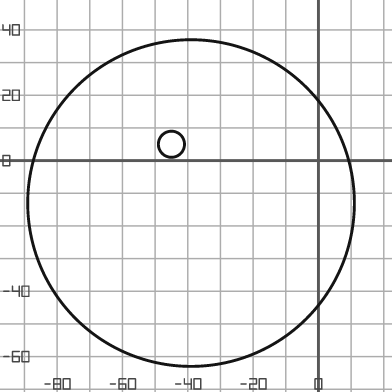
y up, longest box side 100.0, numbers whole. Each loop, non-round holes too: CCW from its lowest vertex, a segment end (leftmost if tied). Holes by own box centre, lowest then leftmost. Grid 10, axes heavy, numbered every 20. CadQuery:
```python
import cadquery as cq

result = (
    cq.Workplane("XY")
    .moveTo(-39.0, -13.0)
    .circle(50.0)
    .moveTo(-45.0, 5.0)
    .circle(4.0)
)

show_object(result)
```